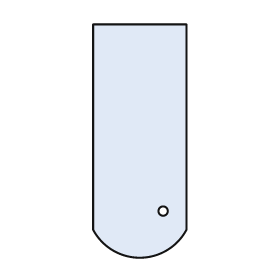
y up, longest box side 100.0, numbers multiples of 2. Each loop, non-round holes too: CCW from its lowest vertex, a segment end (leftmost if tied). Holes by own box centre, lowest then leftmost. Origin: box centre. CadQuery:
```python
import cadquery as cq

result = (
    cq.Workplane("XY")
    .moveTo(-20.0, -38.0)
    .threePointArc((0.0, -50.0), (20.0, -38.0))
    .lineTo(20.0, 50.0)
    .lineTo(-20.0, 50.0)
    .close()
    .moveTo(10.0, -30.0)
    .circle(2.0)
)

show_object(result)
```